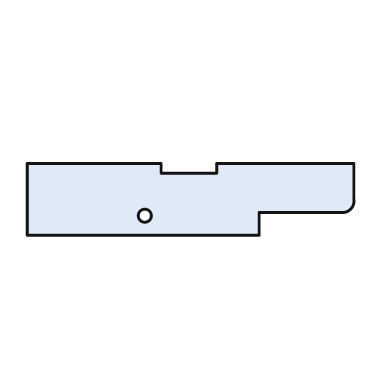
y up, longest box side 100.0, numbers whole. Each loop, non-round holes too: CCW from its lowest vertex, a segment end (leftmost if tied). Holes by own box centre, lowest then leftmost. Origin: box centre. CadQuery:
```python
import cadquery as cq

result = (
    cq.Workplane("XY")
    .moveTo(-50.0, -11.0)
    .lineTo(21.0, -11.0)
    .lineTo(21.0, -4.0)
    .lineTo(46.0, -4.0)
    .threePointArc((49.0, -3.0), (50.0, 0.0))
    .lineTo(50.0, 11.0)
    .lineTo(8.0, 11.0)
    .lineTo(8.0, 8.0)
    .lineTo(-9.0, 8.0)
    .lineTo(-9.0, 11.0)
    .lineTo(-50.0, 11.0)
    .close()
    .moveTo(-14.0, -5.0)
    .circle(2.0)
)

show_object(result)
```